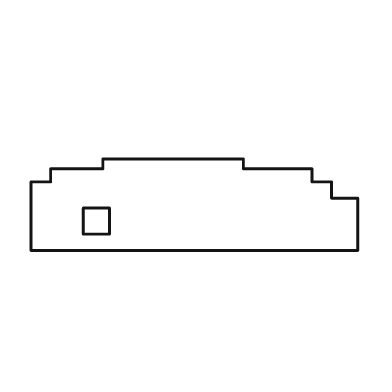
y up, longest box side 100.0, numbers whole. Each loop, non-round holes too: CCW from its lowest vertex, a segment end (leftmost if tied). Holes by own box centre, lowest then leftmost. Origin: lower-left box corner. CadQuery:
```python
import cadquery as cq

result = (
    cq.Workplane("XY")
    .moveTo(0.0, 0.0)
    .lineTo(100.0, 0.0)
    .lineTo(100.0, 16.0)
    .lineTo(92.0, 16.0)
    .lineTo(92.0, 21.0)
    .lineTo(86.0, 21.0)
    .lineTo(86.0, 25.0)
    .lineTo(65.0, 25.0)
    .lineTo(65.0, 28.0)
    .lineTo(22.0, 28.0)
    .lineTo(22.0, 25.0)
    .lineTo(6.0, 25.0)
    .lineTo(6.0, 21.0)
    .lineTo(0.0, 21.0)
    .close()
    .moveTo(16.0, 5.0)
    .lineTo(24.0, 5.0)
    .lineTo(24.0, 13.0)
    .lineTo(16.0, 13.0)
    .close()
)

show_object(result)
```